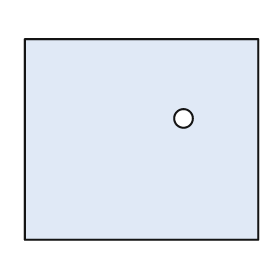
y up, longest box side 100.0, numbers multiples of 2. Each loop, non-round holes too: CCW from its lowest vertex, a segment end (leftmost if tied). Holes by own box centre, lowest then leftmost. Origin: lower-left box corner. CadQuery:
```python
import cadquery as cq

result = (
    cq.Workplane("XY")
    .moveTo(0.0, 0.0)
    .lineTo(100.0, 0.0)
    .lineTo(100.0, 86.0)
    .lineTo(0.0, 86.0)
    .close()
    .moveTo(68.0, 52.0)
    .circle(4.0)
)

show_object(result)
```